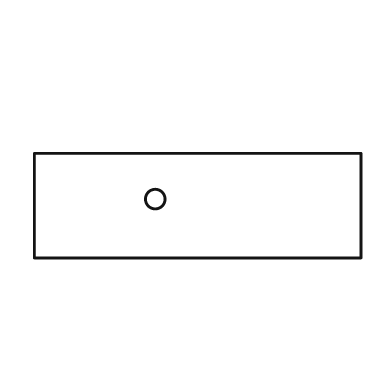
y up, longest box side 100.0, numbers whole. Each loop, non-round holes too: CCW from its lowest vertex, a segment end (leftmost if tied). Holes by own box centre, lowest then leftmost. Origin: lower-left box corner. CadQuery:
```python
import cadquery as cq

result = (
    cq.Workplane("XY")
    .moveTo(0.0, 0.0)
    .lineTo(100.0, 0.0)
    .lineTo(100.0, 32.0)
    .lineTo(0.0, 32.0)
    .close()
    .moveTo(37.0, 18.0)
    .circle(3.0)
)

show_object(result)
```